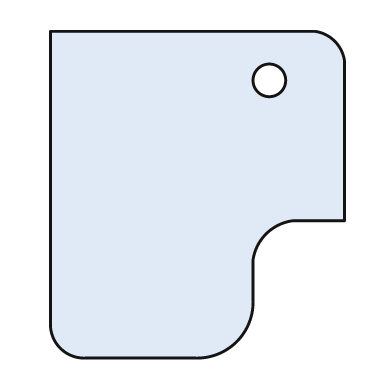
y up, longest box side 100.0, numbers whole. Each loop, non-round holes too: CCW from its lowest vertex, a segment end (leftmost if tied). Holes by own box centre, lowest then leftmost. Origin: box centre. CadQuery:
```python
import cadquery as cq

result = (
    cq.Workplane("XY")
    .moveTo(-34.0, -50.0)
    .lineTo(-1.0, -50.0)
    .threePointArc((12.0, -45.0), (17.0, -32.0))
    .lineTo(17.0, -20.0)
    .threePointArc((21.0, -12.0), (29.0, -8.0))
    .lineTo(45.0, -8.0)
    .lineTo(45.0, 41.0)
    .threePointArc((42.0, 47.0), (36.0, 50.0))
    .lineTo(-45.0, 50.0)
    .lineTo(-45.0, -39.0)
    .threePointArc((-42.0, -47.0), (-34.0, -50.0))
    .close()
    .moveTo(22.0, 35.0)
    .circle(5.0)
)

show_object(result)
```